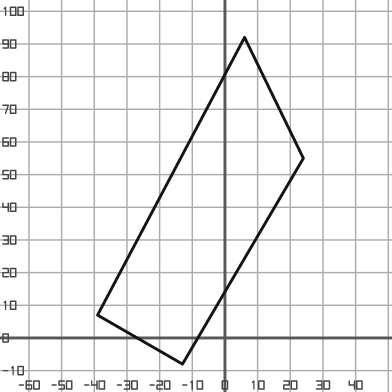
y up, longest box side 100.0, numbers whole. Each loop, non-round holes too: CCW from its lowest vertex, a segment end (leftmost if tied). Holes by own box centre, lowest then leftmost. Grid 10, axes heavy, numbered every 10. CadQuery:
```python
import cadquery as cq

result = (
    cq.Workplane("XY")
    .moveTo(-13.0, -8.0)
    .lineTo(24.0, 55.0)
    .lineTo(6.0, 92.0)
    .lineTo(-39.0, 7.0)
    .close()
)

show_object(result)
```